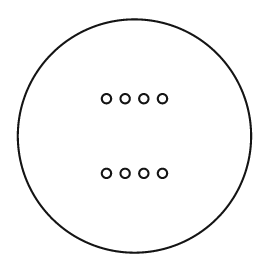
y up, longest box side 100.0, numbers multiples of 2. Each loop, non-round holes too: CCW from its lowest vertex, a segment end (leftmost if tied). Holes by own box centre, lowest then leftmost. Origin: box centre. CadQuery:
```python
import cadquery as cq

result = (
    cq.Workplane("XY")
    .moveTo(0.0, 0.0)
    .circle(50.0)
    .moveTo(-12.0, -16.0)
    .circle(2.0)
    .moveTo(-4.0, -16.0)
    .circle(2.0)
    .moveTo(4.0, -16.0)
    .circle(2.0)
    .moveTo(12.0, -16.0)
    .circle(2.0)
    .moveTo(-12.0, 16.0)
    .circle(2.0)
    .moveTo(-4.0, 16.0)
    .circle(2.0)
    .moveTo(4.0, 16.0)
    .circle(2.0)
    .moveTo(12.0, 16.0)
    .circle(2.0)
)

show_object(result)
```